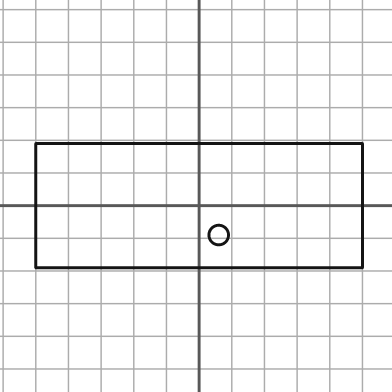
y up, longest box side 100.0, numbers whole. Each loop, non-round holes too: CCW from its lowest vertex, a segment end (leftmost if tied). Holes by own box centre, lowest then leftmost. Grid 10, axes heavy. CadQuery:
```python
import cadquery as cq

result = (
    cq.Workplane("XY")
    .moveTo(-50.0, -19.0)
    .lineTo(50.0, -19.0)
    .lineTo(50.0, 19.0)
    .lineTo(-50.0, 19.0)
    .close()
    .moveTo(6.0, -9.0)
    .circle(3.0)
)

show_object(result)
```